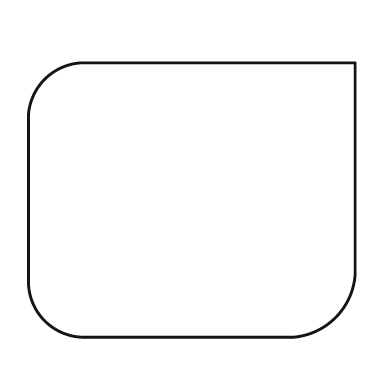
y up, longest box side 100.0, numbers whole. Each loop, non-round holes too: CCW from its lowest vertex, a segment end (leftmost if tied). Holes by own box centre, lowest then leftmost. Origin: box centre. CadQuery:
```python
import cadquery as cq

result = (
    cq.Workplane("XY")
    .moveTo(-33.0, -42.0)
    .lineTo(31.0, -42.0)
    .threePointArc((44.0, -36.0), (50.0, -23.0))
    .lineTo(50.0, 42.0)
    .lineTo(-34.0, 42.0)
    .threePointArc((-45.0, 37.0), (-50.0, 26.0))
    .lineTo(-50.0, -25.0)
    .threePointArc((-45.0, -37.0), (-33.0, -42.0))
    .close()
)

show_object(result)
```